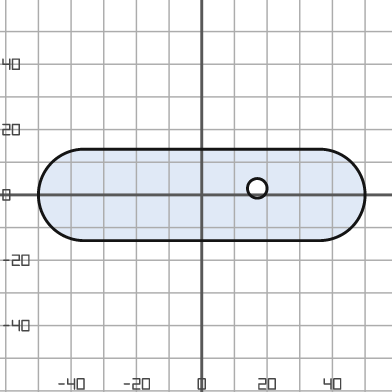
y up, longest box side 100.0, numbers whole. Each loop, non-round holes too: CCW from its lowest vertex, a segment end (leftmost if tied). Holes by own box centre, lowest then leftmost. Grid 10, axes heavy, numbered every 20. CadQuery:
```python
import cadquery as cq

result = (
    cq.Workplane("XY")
    .moveTo(-36.0, -14.0)
    .lineTo(36.0, -14.0)
    .threePointArc((50.0, 0.0), (36.0, 14.0))
    .lineTo(-36.0, 14.0)
    .threePointArc((-50.0, 0.0), (-36.0, -14.0))
    .close()
    .moveTo(17.0, 2.0)
    .circle(3.0)
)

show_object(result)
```